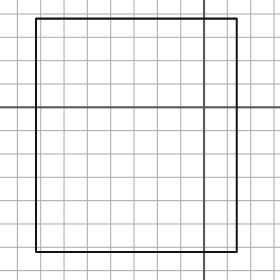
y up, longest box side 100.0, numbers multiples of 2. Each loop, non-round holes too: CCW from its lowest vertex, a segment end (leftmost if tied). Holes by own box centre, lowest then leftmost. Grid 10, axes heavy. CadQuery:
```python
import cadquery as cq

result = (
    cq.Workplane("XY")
    .moveTo(-72.0, -62.0)
    .lineTo(14.0, -62.0)
    .lineTo(14.0, 38.0)
    .lineTo(-72.0, 38.0)
    .close()
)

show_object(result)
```